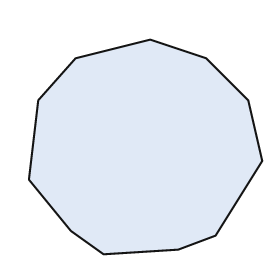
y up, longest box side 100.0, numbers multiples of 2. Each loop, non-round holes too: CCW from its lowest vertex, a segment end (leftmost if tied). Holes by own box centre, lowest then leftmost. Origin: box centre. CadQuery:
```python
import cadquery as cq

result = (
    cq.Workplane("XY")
    .moveTo(-18.0, -46.0)
    .lineTo(14.0, -44.0)
    .lineTo(30.0, -38.0)
    .lineTo(50.0, -6.0)
    .lineTo(44.0, 20.0)
    .lineTo(26.0, 38.0)
    .lineTo(2.0, 46.0)
    .lineTo(-30.0, 38.0)
    .lineTo(-46.0, 20.0)
    .lineTo(-50.0, -14.0)
    .lineTo(-32.0, -36.0)
    .close()
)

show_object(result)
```